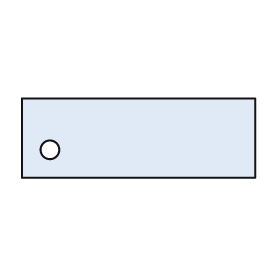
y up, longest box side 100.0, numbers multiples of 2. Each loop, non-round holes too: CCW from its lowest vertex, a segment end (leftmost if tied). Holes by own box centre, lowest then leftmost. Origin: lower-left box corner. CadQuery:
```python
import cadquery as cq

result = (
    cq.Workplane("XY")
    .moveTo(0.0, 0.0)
    .lineTo(100.0, 0.0)
    .lineTo(100.0, 34.0)
    .lineTo(0.0, 34.0)
    .close()
    .moveTo(12.0, 12.0)
    .circle(4.0)
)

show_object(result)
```